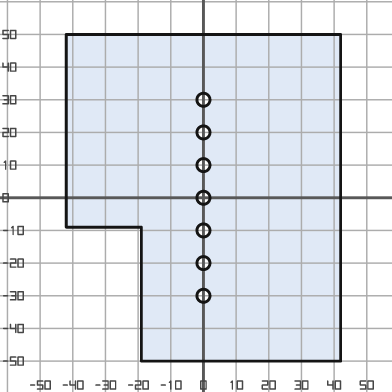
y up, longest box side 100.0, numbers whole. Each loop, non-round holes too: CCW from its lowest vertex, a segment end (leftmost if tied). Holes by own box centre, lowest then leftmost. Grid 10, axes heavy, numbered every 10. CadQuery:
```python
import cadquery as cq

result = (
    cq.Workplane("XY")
    .moveTo(-19.0, -50.0)
    .lineTo(42.0, -50.0)
    .lineTo(42.0, 50.0)
    .lineTo(-42.0, 50.0)
    .lineTo(-42.0, -9.0)
    .lineTo(-19.0, -9.0)
    .close()
    .moveTo(0.0, -30.0)
    .circle(2.0)
    .moveTo(0.0, -20.0)
    .circle(2.0)
    .moveTo(0.0, -10.0)
    .circle(2.0)
    .moveTo(0.0, 0.0)
    .circle(2.0)
    .moveTo(0.0, 10.0)
    .circle(2.0)
    .moveTo(0.0, 20.0)
    .circle(2.0)
    .moveTo(0.0, 30.0)
    .circle(2.0)
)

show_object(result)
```